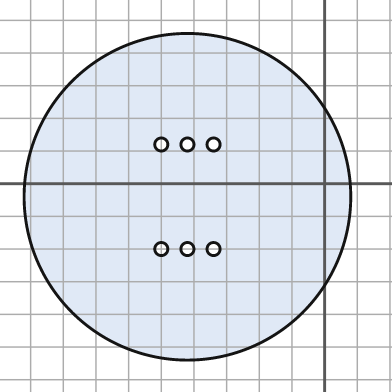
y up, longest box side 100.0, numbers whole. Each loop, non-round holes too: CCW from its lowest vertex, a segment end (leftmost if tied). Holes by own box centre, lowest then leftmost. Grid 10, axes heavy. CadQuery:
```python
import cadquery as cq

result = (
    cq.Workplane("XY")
    .moveTo(-42.0, -4.0)
    .circle(50.0)
    .moveTo(-50.0, -20.0)
    .circle(2.0)
    .moveTo(-42.0, -20.0)
    .circle(2.0)
    .moveTo(-34.0, -20.0)
    .circle(2.0)
    .moveTo(-50.0, 12.0)
    .circle(2.0)
    .moveTo(-42.0, 12.0)
    .circle(2.0)
    .moveTo(-34.0, 12.0)
    .circle(2.0)
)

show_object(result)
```